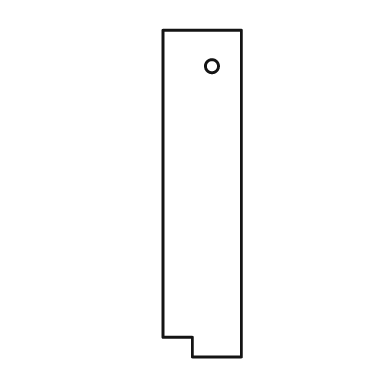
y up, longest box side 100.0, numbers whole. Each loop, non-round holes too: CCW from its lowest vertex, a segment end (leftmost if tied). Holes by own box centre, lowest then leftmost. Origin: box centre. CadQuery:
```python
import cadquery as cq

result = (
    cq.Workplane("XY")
    .moveTo(-3.0, -50.0)
    .lineTo(12.0, -50.0)
    .lineTo(12.0, 50.0)
    .lineTo(-12.0, 50.0)
    .lineTo(-12.0, -44.0)
    .lineTo(-3.0, -44.0)
    .close()
    .moveTo(3.0, 39.0)
    .circle(2.0)
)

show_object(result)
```